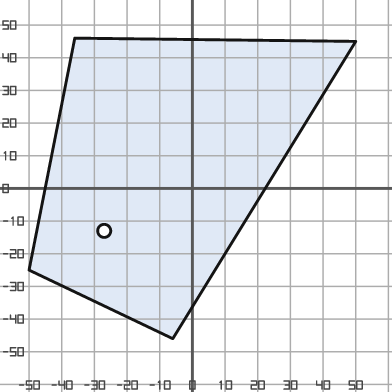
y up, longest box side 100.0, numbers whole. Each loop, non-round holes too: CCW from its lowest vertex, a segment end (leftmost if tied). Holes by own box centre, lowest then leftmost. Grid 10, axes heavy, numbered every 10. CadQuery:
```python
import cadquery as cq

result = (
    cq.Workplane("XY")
    .moveTo(-6.0, -46.0)
    .lineTo(50.0, 45.0)
    .lineTo(-36.0, 46.0)
    .lineTo(-50.0, -25.0)
    .close()
    .moveTo(-27.0, -13.0)
    .circle(2.0)
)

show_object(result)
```